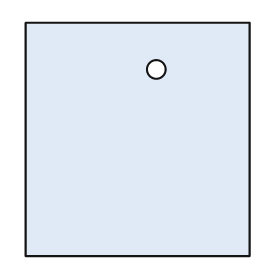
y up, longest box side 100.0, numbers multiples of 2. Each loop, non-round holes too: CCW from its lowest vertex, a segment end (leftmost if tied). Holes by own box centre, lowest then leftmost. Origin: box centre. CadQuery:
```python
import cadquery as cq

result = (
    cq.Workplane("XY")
    .moveTo(-48.0, -50.0)
    .lineTo(48.0, -50.0)
    .lineTo(48.0, 50.0)
    .lineTo(-48.0, 50.0)
    .close()
    .moveTo(8.0, 30.0)
    .circle(4.0)
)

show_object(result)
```